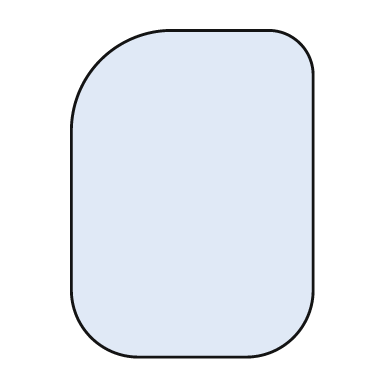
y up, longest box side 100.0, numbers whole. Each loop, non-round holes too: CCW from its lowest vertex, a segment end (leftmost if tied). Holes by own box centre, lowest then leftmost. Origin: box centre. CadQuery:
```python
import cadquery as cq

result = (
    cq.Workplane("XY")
    .moveTo(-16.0, -50.0)
    .lineTo(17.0, -50.0)
    .threePointArc((31.0, -44.0), (37.0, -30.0))
    .lineTo(37.0, 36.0)
    .threePointArc((33.0, 46.0), (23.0, 50.0))
    .lineTo(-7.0, 50.0)
    .threePointArc((-28.0, 41.0), (-37.0, 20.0))
    .lineTo(-37.0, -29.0)
    .threePointArc((-31.0, -44.0), (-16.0, -50.0))
    .close()
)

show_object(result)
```